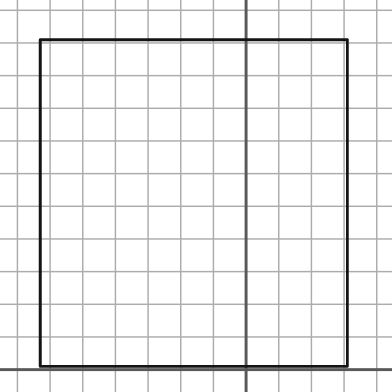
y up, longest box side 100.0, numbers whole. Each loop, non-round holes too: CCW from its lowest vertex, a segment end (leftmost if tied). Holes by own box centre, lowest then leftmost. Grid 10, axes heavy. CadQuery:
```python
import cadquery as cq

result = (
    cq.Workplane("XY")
    .moveTo(-63.0, 1.0)
    .lineTo(31.0, 1.0)
    .lineTo(31.0, 101.0)
    .lineTo(-63.0, 101.0)
    .close()
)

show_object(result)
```